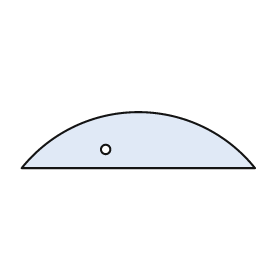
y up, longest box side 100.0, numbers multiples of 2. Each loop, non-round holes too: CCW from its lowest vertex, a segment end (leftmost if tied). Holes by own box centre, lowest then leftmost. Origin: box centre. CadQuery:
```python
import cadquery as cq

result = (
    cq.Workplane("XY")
    .moveTo(-50.0, -12.0)
    .lineTo(50.0, -12.0)
    .threePointArc((0.0, 12.0), (-50.0, -12.0))
    .close()
    .moveTo(-14.0, -4.0)
    .circle(2.0)
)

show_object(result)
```